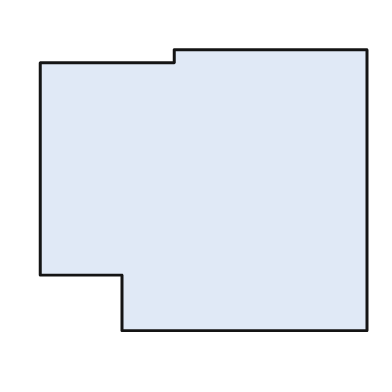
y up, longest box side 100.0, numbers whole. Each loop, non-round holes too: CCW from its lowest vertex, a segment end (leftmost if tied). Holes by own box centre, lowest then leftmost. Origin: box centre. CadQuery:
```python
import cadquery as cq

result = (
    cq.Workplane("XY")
    .moveTo(-25.0, -43.0)
    .lineTo(50.0, -43.0)
    .lineTo(50.0, 43.0)
    .lineTo(-9.0, 43.0)
    .lineTo(-9.0, 39.0)
    .lineTo(-50.0, 39.0)
    .lineTo(-50.0, -26.0)
    .lineTo(-25.0, -26.0)
    .close()
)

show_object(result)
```